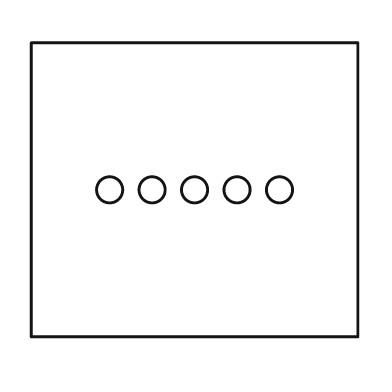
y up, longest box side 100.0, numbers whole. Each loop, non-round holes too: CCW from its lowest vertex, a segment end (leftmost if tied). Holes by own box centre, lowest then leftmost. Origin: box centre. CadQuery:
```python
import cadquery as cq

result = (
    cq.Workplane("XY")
    .moveTo(-50.0, -45.0)
    .lineTo(50.0, -45.0)
    .lineTo(50.0, 45.0)
    .lineTo(-50.0, 45.0)
    .close()
    .moveTo(-26.0, 0.0)
    .circle(4.0)
    .moveTo(-13.0, 0.0)
    .circle(4.0)
    .moveTo(0.0, 0.0)
    .circle(4.0)
    .moveTo(13.0, 0.0)
    .circle(4.0)
    .moveTo(26.0, 0.0)
    .circle(4.0)
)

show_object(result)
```